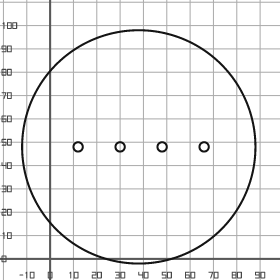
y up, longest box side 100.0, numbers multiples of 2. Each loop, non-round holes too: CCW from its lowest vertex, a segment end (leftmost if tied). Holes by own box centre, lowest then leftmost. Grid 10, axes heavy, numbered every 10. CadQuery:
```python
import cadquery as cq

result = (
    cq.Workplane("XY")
    .moveTo(38.0, 48.0)
    .circle(50.0)
    .moveTo(12.0, 48.0)
    .circle(2.0)
    .moveTo(30.0, 48.0)
    .circle(2.0)
    .moveTo(48.0, 48.0)
    .circle(2.0)
    .moveTo(66.0, 48.0)
    .circle(2.0)
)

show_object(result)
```